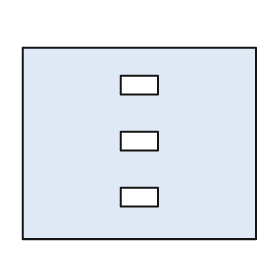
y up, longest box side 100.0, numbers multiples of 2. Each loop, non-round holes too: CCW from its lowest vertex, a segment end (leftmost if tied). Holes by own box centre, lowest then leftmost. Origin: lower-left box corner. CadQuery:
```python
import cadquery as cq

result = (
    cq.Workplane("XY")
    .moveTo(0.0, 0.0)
    .lineTo(100.0, 0.0)
    .lineTo(100.0, 82.0)
    .lineTo(0.0, 82.0)
    .close()
    .moveTo(42.0, 14.0)
    .lineTo(58.0, 14.0)
    .lineTo(58.0, 22.0)
    .lineTo(42.0, 22.0)
    .close()
    .moveTo(42.0, 38.0)
    .lineTo(58.0, 38.0)
    .lineTo(58.0, 46.0)
    .lineTo(42.0, 46.0)
    .close()
    .moveTo(42.0, 62.0)
    .lineTo(58.0, 62.0)
    .lineTo(58.0, 70.0)
    .lineTo(42.0, 70.0)
    .close()
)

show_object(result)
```